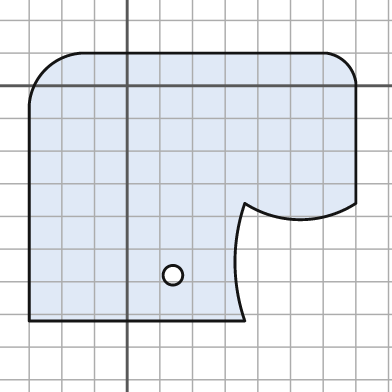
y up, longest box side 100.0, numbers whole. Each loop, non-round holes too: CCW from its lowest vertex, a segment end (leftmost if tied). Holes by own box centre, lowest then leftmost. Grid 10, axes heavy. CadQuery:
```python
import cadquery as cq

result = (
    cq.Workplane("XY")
    .moveTo(-30.0, -72.0)
    .lineTo(36.0, -72.0)
    .threePointArc((33.0, -54.0), (36.0, -36.0))
    .threePointArc((53.0, -41.0), (70.0, -36.0))
    .lineTo(70.0, 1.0)
    .threePointArc((67.0, 7.0), (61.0, 10.0))
    .lineTo(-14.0, 10.0)
    .threePointArc((-25.0, 5.0), (-30.0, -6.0))
    .close()
    .moveTo(14.0, -58.0)
    .circle(3.0)
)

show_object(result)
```